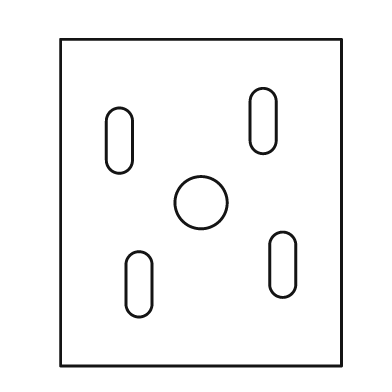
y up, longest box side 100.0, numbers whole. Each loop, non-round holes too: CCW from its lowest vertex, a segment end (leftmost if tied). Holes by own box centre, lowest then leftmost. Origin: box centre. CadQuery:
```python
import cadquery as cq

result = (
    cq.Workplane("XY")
    .moveTo(-43.0, -50.0)
    .lineTo(43.0, -50.0)
    .lineTo(43.0, 50.0)
    .lineTo(-43.0, 50.0)
    .close()
    .moveTo(-23.0, -31.0)
    .threePointArc((-19.0, -35.0), (-15.0, -31.0))
    .lineTo(-15.0, -19.0)
    .threePointArc((-19.0, -15.0), (-23.0, -19.0))
    .close()
    .moveTo(21.0, -25.0)
    .threePointArc((25.0, -29.0), (29.0, -25.0))
    .lineTo(29.0, -13.0)
    .threePointArc((25.0, -9.0), (21.0, -13.0))
    .close()
    .moveTo(0.0, 0.0)
    .circle(8.0)
    .moveTo(-29.0, 13.0)
    .threePointArc((-25.0, 9.0), (-21.0, 13.0))
    .lineTo(-21.0, 25.0)
    .threePointArc((-25.0, 29.0), (-29.0, 25.0))
    .close()
    .moveTo(15.0, 19.0)
    .threePointArc((19.0, 15.0), (23.0, 19.0))
    .lineTo(23.0, 31.0)
    .threePointArc((19.0, 35.0), (15.0, 31.0))
    .close()
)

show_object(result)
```